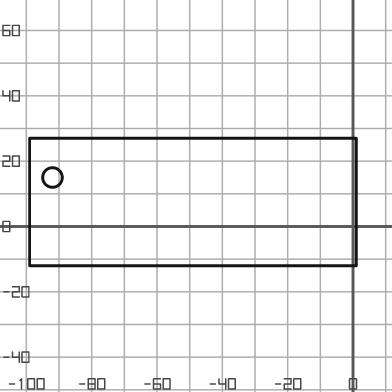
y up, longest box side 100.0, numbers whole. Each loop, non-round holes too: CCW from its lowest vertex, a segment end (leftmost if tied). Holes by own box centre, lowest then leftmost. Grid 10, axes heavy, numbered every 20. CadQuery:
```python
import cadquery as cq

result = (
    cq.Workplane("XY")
    .moveTo(-99.0, -12.0)
    .lineTo(1.0, -12.0)
    .lineTo(1.0, 27.0)
    .lineTo(-99.0, 27.0)
    .close()
    .moveTo(-92.0, 15.0)
    .circle(3.0)
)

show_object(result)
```